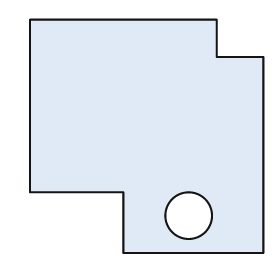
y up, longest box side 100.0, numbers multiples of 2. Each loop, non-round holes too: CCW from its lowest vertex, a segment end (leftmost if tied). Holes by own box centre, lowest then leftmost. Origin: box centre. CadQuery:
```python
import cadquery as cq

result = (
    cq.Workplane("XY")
    .moveTo(-10.0, -50.0)
    .lineTo(50.0, -50.0)
    .lineTo(50.0, 34.0)
    .lineTo(30.0, 34.0)
    .lineTo(30.0, 50.0)
    .lineTo(-50.0, 50.0)
    .lineTo(-50.0, -24.0)
    .lineTo(-10.0, -24.0)
    .close()
    .moveTo(18.0, -34.0)
    .circle(10.0)
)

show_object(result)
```